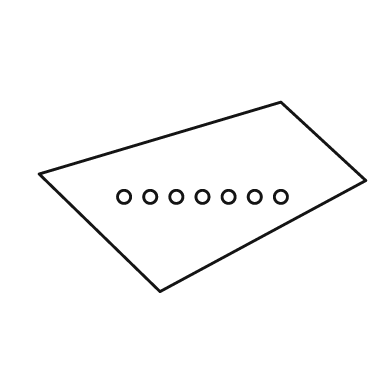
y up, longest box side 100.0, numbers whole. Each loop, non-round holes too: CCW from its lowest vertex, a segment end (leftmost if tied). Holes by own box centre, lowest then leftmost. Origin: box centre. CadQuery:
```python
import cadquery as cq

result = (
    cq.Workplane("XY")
    .moveTo(-13.0, -29.0)
    .lineTo(50.0, 5.0)
    .lineTo(24.0, 29.0)
    .lineTo(-50.0, 7.0)
    .close()
    .moveTo(-24.0, 0.0)
    .circle(2.0)
    .moveTo(-16.0, 0.0)
    .circle(2.0)
    .moveTo(-8.0, 0.0)
    .circle(2.0)
    .moveTo(0.0, 0.0)
    .circle(2.0)
    .moveTo(8.0, 0.0)
    .circle(2.0)
    .moveTo(16.0, 0.0)
    .circle(2.0)
    .moveTo(24.0, 0.0)
    .circle(2.0)
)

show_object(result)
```